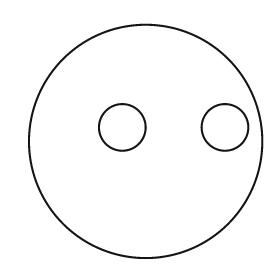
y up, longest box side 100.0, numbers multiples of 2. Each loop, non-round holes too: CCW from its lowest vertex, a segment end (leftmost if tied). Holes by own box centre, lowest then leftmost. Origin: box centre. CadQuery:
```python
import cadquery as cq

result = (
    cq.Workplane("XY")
    .moveTo(0.0, 0.0)
    .circle(50.0)
    .moveTo(-10.0, 6.0)
    .circle(10.0)
    .moveTo(34.0, 6.0)
    .circle(10.0)
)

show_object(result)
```